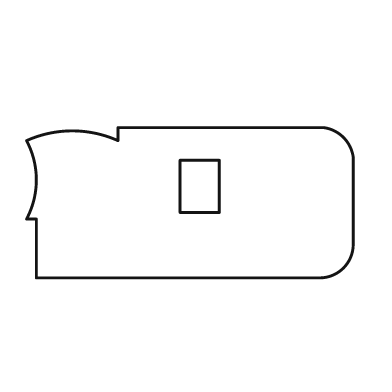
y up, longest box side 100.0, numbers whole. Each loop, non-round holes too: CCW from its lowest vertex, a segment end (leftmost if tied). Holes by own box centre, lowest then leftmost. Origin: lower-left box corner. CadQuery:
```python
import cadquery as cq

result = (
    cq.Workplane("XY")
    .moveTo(3.0, 0.0)
    .lineTo(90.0, 0.0)
    .threePointArc((97.0, 3.0), (100.0, 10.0))
    .lineTo(100.0, 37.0)
    .threePointArc((97.0, 43.0), (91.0, 46.0))
    .lineTo(28.0, 46.0)
    .lineTo(28.0, 42.0)
    .threePointArc((14.0, 45.0), (0.0, 42.0))
    .threePointArc((3.0, 30.0), (0.0, 18.0))
    .lineTo(3.0, 18.0)
    .close()
    .moveTo(47.0, 20.0)
    .lineTo(59.0, 20.0)
    .lineTo(59.0, 36.0)
    .lineTo(47.0, 36.0)
    .close()
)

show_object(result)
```